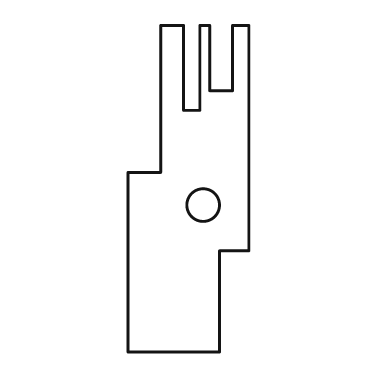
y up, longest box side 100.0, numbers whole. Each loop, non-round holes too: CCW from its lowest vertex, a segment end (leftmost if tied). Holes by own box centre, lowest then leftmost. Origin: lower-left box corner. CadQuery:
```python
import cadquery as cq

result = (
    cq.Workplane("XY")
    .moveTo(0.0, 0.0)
    .lineTo(28.0, 0.0)
    .lineTo(28.0, 31.0)
    .lineTo(37.0, 31.0)
    .lineTo(37.0, 100.0)
    .lineTo(32.0, 100.0)
    .lineTo(32.0, 80.0)
    .lineTo(25.0, 80.0)
    .lineTo(25.0, 100.0)
    .lineTo(22.0, 100.0)
    .lineTo(22.0, 74.0)
    .lineTo(17.0, 74.0)
    .lineTo(17.0, 100.0)
    .lineTo(10.0, 100.0)
    .lineTo(10.0, 55.0)
    .lineTo(0.0, 55.0)
    .close()
    .moveTo(23.0, 45.0)
    .circle(5.0)
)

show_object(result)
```